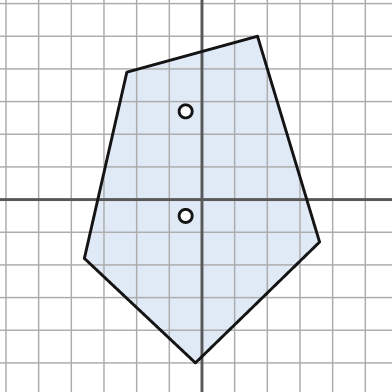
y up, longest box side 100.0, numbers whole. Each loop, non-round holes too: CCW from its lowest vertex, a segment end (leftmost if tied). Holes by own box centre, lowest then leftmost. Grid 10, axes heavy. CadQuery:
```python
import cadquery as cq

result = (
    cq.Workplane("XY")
    .moveTo(-2.0, -50.0)
    .lineTo(36.0, -13.0)
    .lineTo(17.0, 50.0)
    .lineTo(-23.0, 39.0)
    .lineTo(-36.0, -18.0)
    .close()
    .moveTo(-5.0, -5.0)
    .circle(2.0)
    .moveTo(-5.0, 27.0)
    .circle(2.0)
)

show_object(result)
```